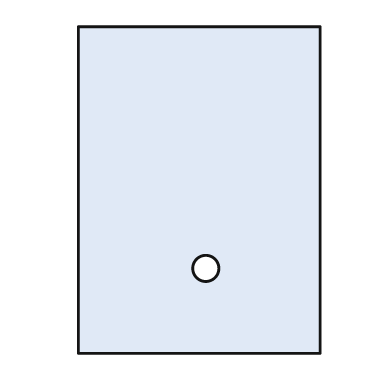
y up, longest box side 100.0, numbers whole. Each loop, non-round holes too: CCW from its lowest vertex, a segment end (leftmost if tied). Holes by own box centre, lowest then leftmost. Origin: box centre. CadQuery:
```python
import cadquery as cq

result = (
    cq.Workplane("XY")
    .moveTo(-37.0, -50.0)
    .lineTo(37.0, -50.0)
    .lineTo(37.0, 50.0)
    .lineTo(-37.0, 50.0)
    .close()
    .moveTo(2.0, -24.0)
    .circle(4.0)
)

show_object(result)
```